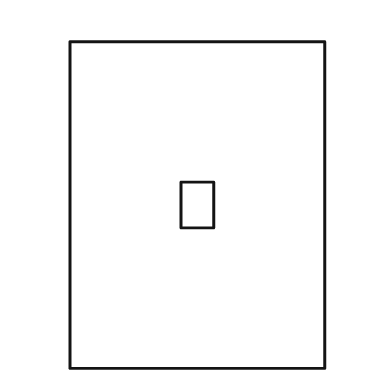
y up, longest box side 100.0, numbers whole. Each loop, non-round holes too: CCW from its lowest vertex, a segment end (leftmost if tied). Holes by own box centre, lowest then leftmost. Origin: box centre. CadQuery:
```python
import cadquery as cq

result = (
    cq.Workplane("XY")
    .moveTo(-39.0, -50.0)
    .lineTo(39.0, -50.0)
    .lineTo(39.0, 50.0)
    .lineTo(-39.0, 50.0)
    .close()
    .moveTo(-5.0, -7.0)
    .lineTo(5.0, -7.0)
    .lineTo(5.0, 7.0)
    .lineTo(-5.0, 7.0)
    .close()
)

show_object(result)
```